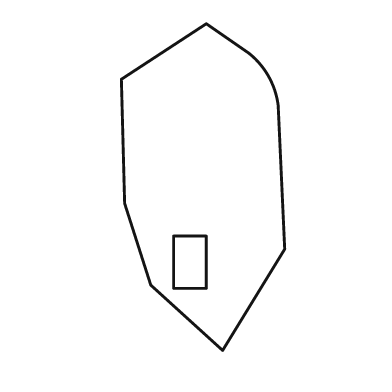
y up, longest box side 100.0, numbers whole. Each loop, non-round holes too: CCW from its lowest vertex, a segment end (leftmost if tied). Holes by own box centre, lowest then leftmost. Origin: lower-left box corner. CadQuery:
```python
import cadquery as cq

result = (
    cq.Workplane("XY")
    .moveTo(31.0, 0.0)
    .lineTo(50.0, 31.0)
    .lineTo(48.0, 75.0)
    .threePointArc((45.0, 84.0), (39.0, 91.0))
    .lineTo(26.0, 100.0)
    .lineTo(0.0, 83.0)
    .lineTo(1.0, 45.0)
    .lineTo(9.0, 20.0)
    .close()
    .moveTo(16.0, 19.0)
    .lineTo(26.0, 19.0)
    .lineTo(26.0, 35.0)
    .lineTo(16.0, 35.0)
    .close()
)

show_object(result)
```